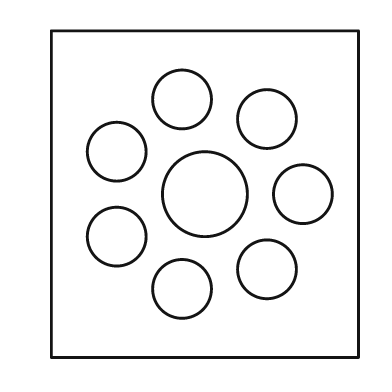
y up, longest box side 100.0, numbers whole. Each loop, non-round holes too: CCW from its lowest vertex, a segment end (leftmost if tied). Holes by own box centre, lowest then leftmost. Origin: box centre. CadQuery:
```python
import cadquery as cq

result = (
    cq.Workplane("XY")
    .moveTo(-47.0, -50.0)
    .lineTo(47.0, -50.0)
    .lineTo(47.0, 50.0)
    .lineTo(-47.0, 50.0)
    .close()
    .moveTo(-7.0, -29.0)
    .circle(9.0)
    .moveTo(19.0, -23.0)
    .circle(9.0)
    .moveTo(-27.0, -13.0)
    .circle(9.0)
    .moveTo(0.0, 0.0)
    .circle(13.0)
    .moveTo(30.0, 0.0)
    .circle(9.0)
    .moveTo(-27.0, 13.0)
    .circle(9.0)
    .moveTo(19.0, 23.0)
    .circle(9.0)
    .moveTo(-7.0, 29.0)
    .circle(9.0)
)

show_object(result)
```